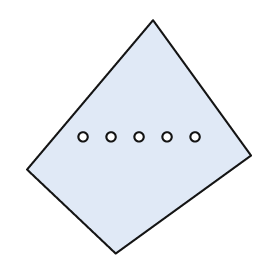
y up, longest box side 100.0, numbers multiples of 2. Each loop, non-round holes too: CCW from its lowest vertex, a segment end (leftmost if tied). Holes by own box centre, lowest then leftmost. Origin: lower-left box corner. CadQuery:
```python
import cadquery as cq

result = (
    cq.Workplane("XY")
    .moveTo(38.0, 0.0)
    .lineTo(96.0, 42.0)
    .lineTo(54.0, 100.0)
    .lineTo(0.0, 36.0)
    .close()
    .moveTo(24.0, 50.0)
    .circle(2.0)
    .moveTo(36.0, 50.0)
    .circle(2.0)
    .moveTo(48.0, 50.0)
    .circle(2.0)
    .moveTo(60.0, 50.0)
    .circle(2.0)
    .moveTo(72.0, 50.0)
    .circle(2.0)
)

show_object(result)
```